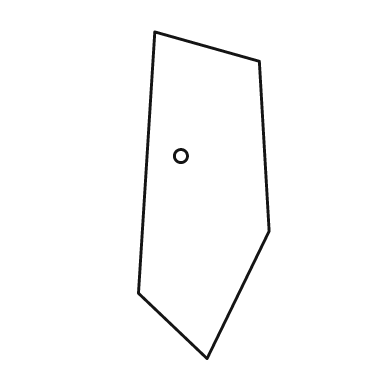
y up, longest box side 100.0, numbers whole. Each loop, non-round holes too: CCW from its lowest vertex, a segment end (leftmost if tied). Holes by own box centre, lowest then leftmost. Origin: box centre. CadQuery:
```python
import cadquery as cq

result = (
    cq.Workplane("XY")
    .moveTo(1.0, -50.0)
    .lineTo(20.0, -11.0)
    .lineTo(17.0, 41.0)
    .lineTo(-15.0, 50.0)
    .lineTo(-20.0, -30.0)
    .close()
    .moveTo(-7.0, 12.0)
    .circle(2.0)
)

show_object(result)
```